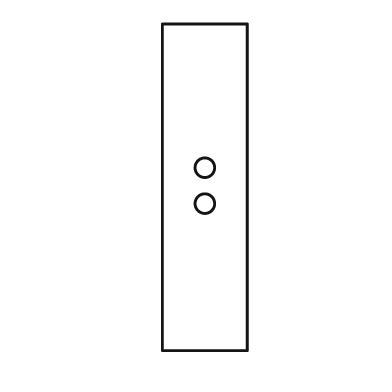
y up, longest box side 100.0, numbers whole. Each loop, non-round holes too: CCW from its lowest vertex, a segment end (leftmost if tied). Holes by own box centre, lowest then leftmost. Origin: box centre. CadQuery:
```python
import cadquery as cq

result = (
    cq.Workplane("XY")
    .moveTo(-13.0, -50.0)
    .lineTo(13.0, -50.0)
    .lineTo(13.0, 50.0)
    .lineTo(-13.0, 50.0)
    .close()
    .moveTo(0.0, -5.0)
    .circle(3.0)
    .moveTo(0.0, 6.0)
    .circle(3.0)
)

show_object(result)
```